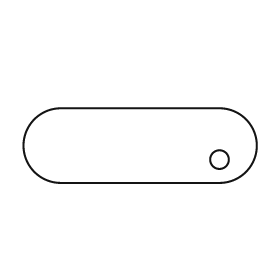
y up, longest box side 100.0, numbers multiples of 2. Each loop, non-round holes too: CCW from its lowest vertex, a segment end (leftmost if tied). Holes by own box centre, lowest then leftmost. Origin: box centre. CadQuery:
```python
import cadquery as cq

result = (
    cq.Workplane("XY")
    .moveTo(-34.0, -16.0)
    .lineTo(34.0, -16.0)
    .threePointArc((50.0, 0.0), (34.0, 16.0))
    .lineTo(-34.0, 16.0)
    .threePointArc((-50.0, 0.0), (-34.0, -16.0))
    .close()
    .moveTo(34.0, -6.0)
    .circle(4.0)
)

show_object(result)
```